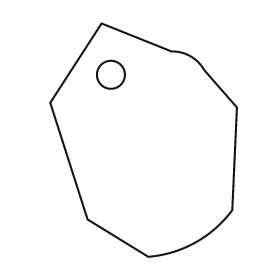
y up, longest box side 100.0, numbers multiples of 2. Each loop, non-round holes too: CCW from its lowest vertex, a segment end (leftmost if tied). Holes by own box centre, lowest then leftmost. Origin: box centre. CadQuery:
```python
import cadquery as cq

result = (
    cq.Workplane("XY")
    .moveTo(2.0, -50.0)
    .threePointArc((22.0, -44.0), (38.0, -30.0))
    .lineTo(40.0, 14.0)
    .lineTo(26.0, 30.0)
    .threePointArc((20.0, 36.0), (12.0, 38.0))
    .lineTo(-18.0, 50.0)
    .lineTo(-40.0, 16.0)
    .lineTo(-24.0, -34.0)
    .close()
    .moveTo(-14.0, 28.0)
    .circle(6.0)
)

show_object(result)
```